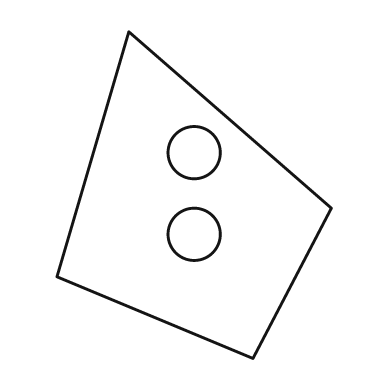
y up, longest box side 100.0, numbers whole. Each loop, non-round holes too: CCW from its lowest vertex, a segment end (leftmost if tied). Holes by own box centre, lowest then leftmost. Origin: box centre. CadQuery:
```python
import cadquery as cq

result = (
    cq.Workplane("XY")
    .moveTo(18.0, -50.0)
    .lineTo(42.0, -4.0)
    .lineTo(-20.0, 50.0)
    .lineTo(-42.0, -25.0)
    .close()
    .moveTo(0.0, -12.0)
    .circle(8.0)
    .moveTo(0.0, 13.0)
    .circle(8.0)
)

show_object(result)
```